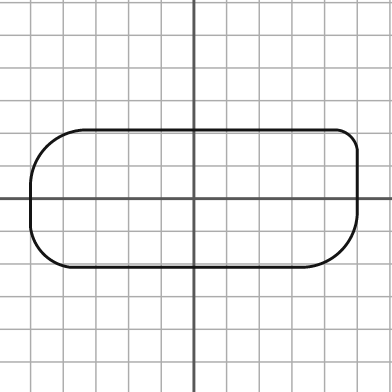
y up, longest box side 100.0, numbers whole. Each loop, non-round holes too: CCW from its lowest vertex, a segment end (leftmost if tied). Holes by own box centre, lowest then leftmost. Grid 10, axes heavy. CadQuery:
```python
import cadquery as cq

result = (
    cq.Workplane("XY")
    .moveTo(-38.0, -21.0)
    .lineTo(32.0, -21.0)
    .threePointArc((45.0, -16.0), (50.0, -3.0))
    .lineTo(50.0, 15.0)
    .threePointArc((48.0, 19.0), (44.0, 21.0))
    .lineTo(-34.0, 21.0)
    .threePointArc((-45.0, 16.0), (-50.0, 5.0))
    .lineTo(-50.0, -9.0)
    .threePointArc((-46.0, -17.0), (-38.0, -21.0))
    .close()
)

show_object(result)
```